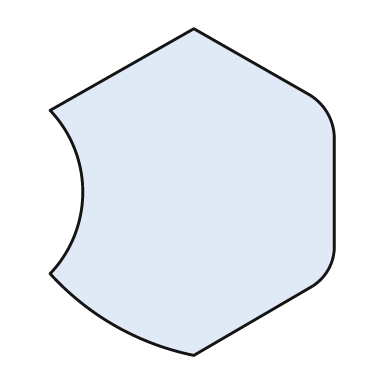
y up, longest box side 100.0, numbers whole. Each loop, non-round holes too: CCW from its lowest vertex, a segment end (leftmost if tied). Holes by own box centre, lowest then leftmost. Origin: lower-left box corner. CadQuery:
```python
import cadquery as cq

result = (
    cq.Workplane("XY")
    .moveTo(44.0, 0.0)
    .lineTo(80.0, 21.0)
    .threePointArc((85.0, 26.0), (87.0, 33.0))
    .lineTo(87.0, 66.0)
    .threePointArc((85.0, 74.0), (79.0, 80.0))
    .lineTo(44.0, 100.0)
    .lineTo(0.0, 75.0)
    .threePointArc((10.0, 50.0), (0.0, 25.0))
    .threePointArc((20.0, 9.0), (44.0, 0.0))
    .close()
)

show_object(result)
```